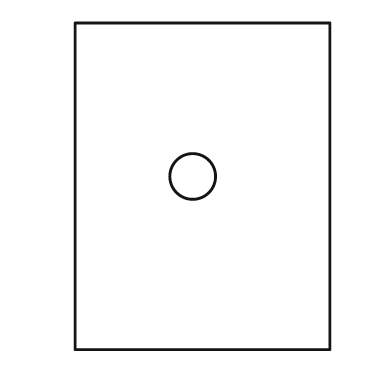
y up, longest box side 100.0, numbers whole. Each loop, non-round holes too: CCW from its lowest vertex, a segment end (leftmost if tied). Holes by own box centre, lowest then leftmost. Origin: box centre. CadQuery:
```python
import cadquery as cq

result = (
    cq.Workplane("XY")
    .moveTo(-39.0, -50.0)
    .lineTo(39.0, -50.0)
    .lineTo(39.0, 50.0)
    .lineTo(-39.0, 50.0)
    .close()
    .moveTo(-3.0, 3.0)
    .circle(7.0)
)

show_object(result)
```